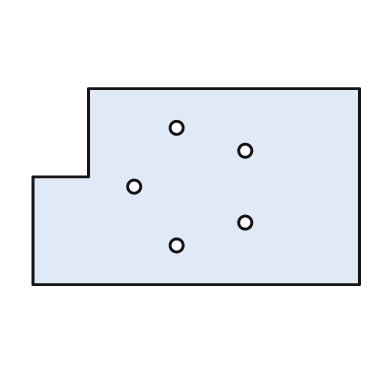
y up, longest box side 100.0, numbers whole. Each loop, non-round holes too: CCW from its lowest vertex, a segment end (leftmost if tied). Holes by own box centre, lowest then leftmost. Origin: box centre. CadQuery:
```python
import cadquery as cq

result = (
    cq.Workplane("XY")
    .moveTo(-50.0, -30.0)
    .lineTo(50.0, -30.0)
    .lineTo(50.0, 30.0)
    .lineTo(-33.0, 30.0)
    .lineTo(-33.0, 3.0)
    .lineTo(-50.0, 3.0)
    .close()
    .moveTo(-6.0, -18.0)
    .circle(2.0)
    .moveTo(15.0, -11.0)
    .circle(2.0)
    .moveTo(-19.0, 0.0)
    .circle(2.0)
    .moveTo(15.0, 11.0)
    .circle(2.0)
    .moveTo(-6.0, 18.0)
    .circle(2.0)
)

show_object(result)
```